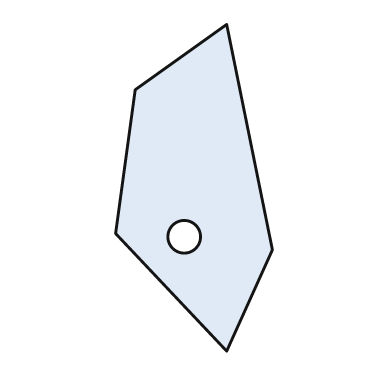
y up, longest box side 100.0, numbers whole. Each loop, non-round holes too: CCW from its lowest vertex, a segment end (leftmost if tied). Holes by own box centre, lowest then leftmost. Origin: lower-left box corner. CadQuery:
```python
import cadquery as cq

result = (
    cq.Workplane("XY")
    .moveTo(34.0, 0.0)
    .lineTo(48.0, 31.0)
    .lineTo(34.0, 100.0)
    .lineTo(6.0, 80.0)
    .lineTo(0.0, 36.0)
    .close()
    .moveTo(21.0, 35.0)
    .circle(5.0)
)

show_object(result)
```